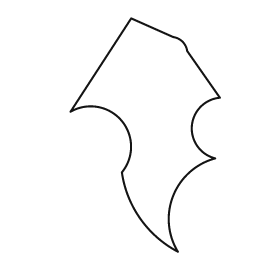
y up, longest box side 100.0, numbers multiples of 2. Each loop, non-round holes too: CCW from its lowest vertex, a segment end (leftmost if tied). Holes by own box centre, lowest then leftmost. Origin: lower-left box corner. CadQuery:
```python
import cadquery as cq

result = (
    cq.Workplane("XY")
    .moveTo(46.0, 0.0)
    .threePointArc((44.0, 24.0), (62.0, 40.0))
    .threePointArc((52.0, 54.0), (64.0, 66.0))
    .lineTo(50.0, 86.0)
    .threePointArc((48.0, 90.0), (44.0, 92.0))
    .lineTo(26.0, 100.0)
    .lineTo(0.0, 60.0)
    .threePointArc((22.0, 56.0), (22.0, 34.0))
    .threePointArc((30.0, 14.0), (46.0, 0.0))
    .close()
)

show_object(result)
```